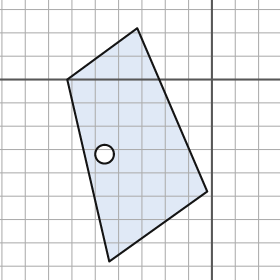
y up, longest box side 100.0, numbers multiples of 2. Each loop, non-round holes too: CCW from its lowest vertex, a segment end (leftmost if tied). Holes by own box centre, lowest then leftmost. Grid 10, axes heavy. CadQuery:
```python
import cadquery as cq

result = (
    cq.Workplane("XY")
    .moveTo(-44.0, -78.0)
    .lineTo(-2.0, -48.0)
    .lineTo(-32.0, 22.0)
    .lineTo(-62.0, 0.0)
    .close()
    .moveTo(-46.0, -32.0)
    .circle(4.0)
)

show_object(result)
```